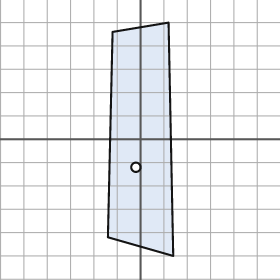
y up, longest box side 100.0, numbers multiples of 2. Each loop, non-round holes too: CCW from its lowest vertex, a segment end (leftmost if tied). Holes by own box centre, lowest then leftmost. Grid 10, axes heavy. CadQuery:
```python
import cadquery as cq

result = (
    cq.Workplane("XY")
    .moveTo(14.0, -50.0)
    .lineTo(12.0, 50.0)
    .lineTo(-12.0, 46.0)
    .lineTo(-14.0, -42.0)
    .close()
    .moveTo(-2.0, -12.0)
    .circle(2.0)
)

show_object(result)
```